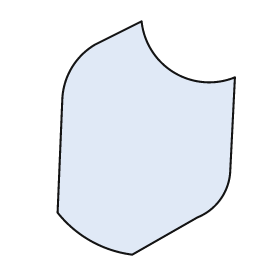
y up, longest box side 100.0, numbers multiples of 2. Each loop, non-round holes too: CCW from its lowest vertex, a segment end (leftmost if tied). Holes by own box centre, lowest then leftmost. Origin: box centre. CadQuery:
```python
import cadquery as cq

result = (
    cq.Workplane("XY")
    .moveTo(-6.0, -50.0)
    .lineTo(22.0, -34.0)
    .threePointArc((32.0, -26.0), (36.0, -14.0))
    .lineTo(38.0, 26.0)
    .threePointArc((12.0, 28.0), (-2.0, 50.0))
    .lineTo(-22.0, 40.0)
    .threePointArc((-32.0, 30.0), (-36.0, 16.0))
    .lineTo(-38.0, -32.0)
    .threePointArc((-24.0, -44.0), (-6.0, -50.0))
    .close()
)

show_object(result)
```